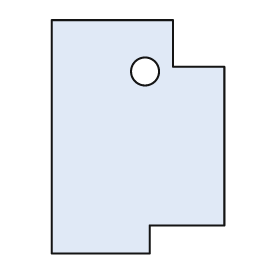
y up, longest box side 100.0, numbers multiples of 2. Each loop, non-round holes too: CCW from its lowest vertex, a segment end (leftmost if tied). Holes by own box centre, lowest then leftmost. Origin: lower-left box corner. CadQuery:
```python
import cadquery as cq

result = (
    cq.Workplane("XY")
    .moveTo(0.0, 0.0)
    .lineTo(42.0, 0.0)
    .lineTo(42.0, 12.0)
    .lineTo(74.0, 12.0)
    .lineTo(74.0, 80.0)
    .lineTo(52.0, 80.0)
    .lineTo(52.0, 100.0)
    .lineTo(0.0, 100.0)
    .close()
    .moveTo(40.0, 78.0)
    .circle(6.0)
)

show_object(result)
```